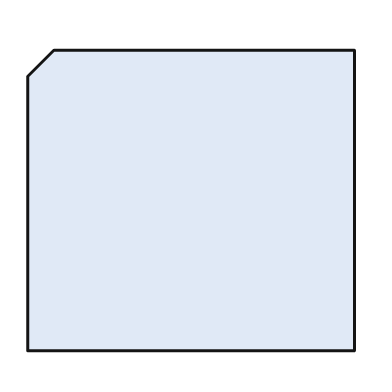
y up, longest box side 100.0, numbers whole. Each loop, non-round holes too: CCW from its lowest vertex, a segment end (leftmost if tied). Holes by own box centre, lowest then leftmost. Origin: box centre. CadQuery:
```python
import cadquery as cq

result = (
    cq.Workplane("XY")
    .moveTo(-50.0, -46.0)
    .lineTo(50.0, -46.0)
    .lineTo(50.0, 46.0)
    .lineTo(-42.0, 46.0)
    .lineTo(-50.0, 38.0)
    .close()
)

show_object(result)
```